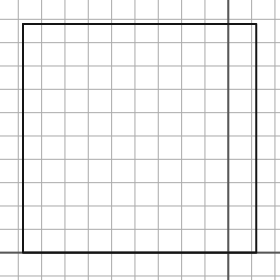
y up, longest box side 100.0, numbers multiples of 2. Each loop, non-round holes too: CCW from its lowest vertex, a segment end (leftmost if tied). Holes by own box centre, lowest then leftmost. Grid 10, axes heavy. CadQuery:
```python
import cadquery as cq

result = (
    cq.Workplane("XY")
    .moveTo(-88.0, 0.0)
    .lineTo(12.0, 0.0)
    .lineTo(12.0, 98.0)
    .lineTo(-88.0, 98.0)
    .close()
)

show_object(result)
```